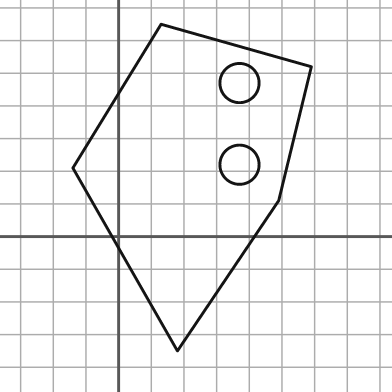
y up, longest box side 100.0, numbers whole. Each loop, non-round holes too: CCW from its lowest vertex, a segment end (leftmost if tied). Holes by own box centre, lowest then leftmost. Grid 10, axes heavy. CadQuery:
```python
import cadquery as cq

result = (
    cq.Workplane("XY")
    .moveTo(18.0, -35.0)
    .lineTo(49.0, 11.0)
    .lineTo(59.0, 52.0)
    .lineTo(13.0, 65.0)
    .lineTo(-14.0, 21.0)
    .close()
    .moveTo(37.0, 22.0)
    .circle(6.0)
    .moveTo(37.0, 47.0)
    .circle(6.0)
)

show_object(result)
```